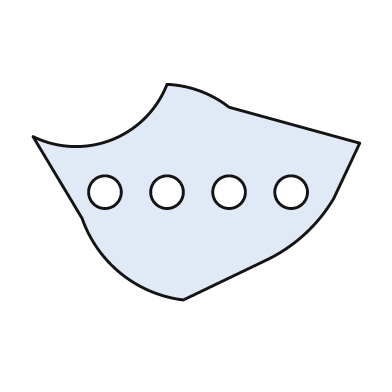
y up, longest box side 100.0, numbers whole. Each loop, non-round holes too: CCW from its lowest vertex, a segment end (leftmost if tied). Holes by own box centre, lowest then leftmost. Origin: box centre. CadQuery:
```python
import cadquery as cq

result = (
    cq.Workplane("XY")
    .moveTo(-4.0, -33.0)
    .lineTo(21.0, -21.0)
    .threePointArc((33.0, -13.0), (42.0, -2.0))
    .lineTo(50.0, 15.0)
    .lineTo(10.0, 26.0)
    .threePointArc((1.0, 31.0), (-9.0, 33.0))
    .threePointArc((-26.0, 16.0), (-50.0, 17.0))
    .lineTo(-35.0, -8.0)
    .threePointArc((-23.0, -25.0), (-4.0, -33.0))
    .close()
    .moveTo(-28.0, 0.0)
    .circle(5.0)
    .moveTo(-9.0, 0.0)
    .circle(5.0)
    .moveTo(10.0, 0.0)
    .circle(5.0)
    .moveTo(29.0, 0.0)
    .circle(5.0)
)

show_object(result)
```